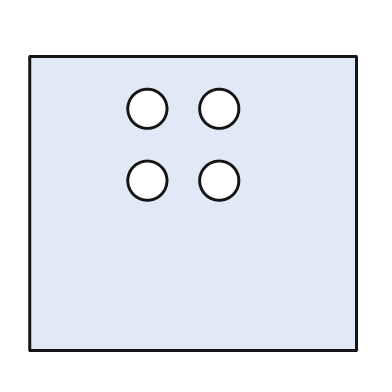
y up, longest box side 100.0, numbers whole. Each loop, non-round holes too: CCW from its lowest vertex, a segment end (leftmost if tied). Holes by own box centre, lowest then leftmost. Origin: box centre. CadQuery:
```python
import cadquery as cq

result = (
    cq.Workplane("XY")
    .moveTo(-50.0, -45.0)
    .lineTo(50.0, -45.0)
    .lineTo(50.0, 45.0)
    .lineTo(-50.0, 45.0)
    .close()
    .moveTo(-14.0, 7.0)
    .circle(6.0)
    .moveTo(8.0, 7.0)
    .circle(6.0)
    .moveTo(-14.0, 29.0)
    .circle(6.0)
    .moveTo(8.0, 29.0)
    .circle(6.0)
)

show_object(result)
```